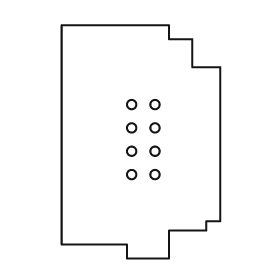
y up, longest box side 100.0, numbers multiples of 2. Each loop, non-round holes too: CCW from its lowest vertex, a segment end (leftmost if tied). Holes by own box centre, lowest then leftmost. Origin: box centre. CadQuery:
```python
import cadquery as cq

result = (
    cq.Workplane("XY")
    .moveTo(-6.0, -50.0)
    .lineTo(12.0, -50.0)
    .lineTo(12.0, -38.0)
    .lineTo(28.0, -38.0)
    .lineTo(28.0, -34.0)
    .lineTo(34.0, -34.0)
    .lineTo(34.0, 32.0)
    .lineTo(22.0, 32.0)
    .lineTo(22.0, 44.0)
    .lineTo(12.0, 44.0)
    .lineTo(12.0, 50.0)
    .lineTo(-34.0, 50.0)
    .lineTo(-34.0, -44.0)
    .lineTo(-6.0, -44.0)
    .close()
    .moveTo(-4.0, -14.0)
    .circle(2.0)
    .moveTo(6.0, -14.0)
    .circle(2.0)
    .moveTo(-4.0, -4.0)
    .circle(2.0)
    .moveTo(6.0, -4.0)
    .circle(2.0)
    .moveTo(-4.0, 6.0)
    .circle(2.0)
    .moveTo(6.0, 6.0)
    .circle(2.0)
    .moveTo(-4.0, 16.0)
    .circle(2.0)
    .moveTo(6.0, 16.0)
    .circle(2.0)
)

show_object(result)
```